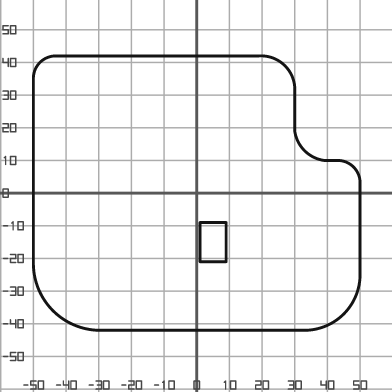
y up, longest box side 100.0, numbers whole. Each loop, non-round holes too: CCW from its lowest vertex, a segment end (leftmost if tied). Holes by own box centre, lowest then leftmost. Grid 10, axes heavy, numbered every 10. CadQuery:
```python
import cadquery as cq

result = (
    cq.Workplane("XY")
    .moveTo(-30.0, -42.0)
    .lineTo(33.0, -42.0)
    .threePointArc((45.0, -37.0), (50.0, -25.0))
    .lineTo(50.0, 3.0)
    .threePointArc((48.0, 8.0), (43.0, 10.0))
    .lineTo(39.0, 10.0)
    .threePointArc((33.0, 13.0), (30.0, 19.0))
    .lineTo(30.0, 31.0)
    .threePointArc((27.0, 39.0), (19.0, 42.0))
    .lineTo(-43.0, 42.0)
    .threePointArc((-48.0, 40.0), (-50.0, 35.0))
    .lineTo(-50.0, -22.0)
    .threePointArc((-44.0, -36.0), (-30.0, -42.0))
    .close()
    .moveTo(1.0, -21.0)
    .lineTo(9.0, -21.0)
    .lineTo(9.0, -9.0)
    .lineTo(1.0, -9.0)
    .close()
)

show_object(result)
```